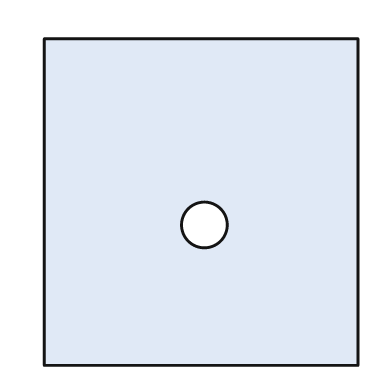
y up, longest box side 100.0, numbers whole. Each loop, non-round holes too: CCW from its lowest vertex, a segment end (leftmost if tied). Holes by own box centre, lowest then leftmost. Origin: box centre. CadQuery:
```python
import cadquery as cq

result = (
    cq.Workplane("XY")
    .moveTo(-48.0, -50.0)
    .lineTo(48.0, -50.0)
    .lineTo(48.0, 50.0)
    .lineTo(-48.0, 50.0)
    .close()
    .moveTo(1.0, -7.0)
    .circle(7.0)
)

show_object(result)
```